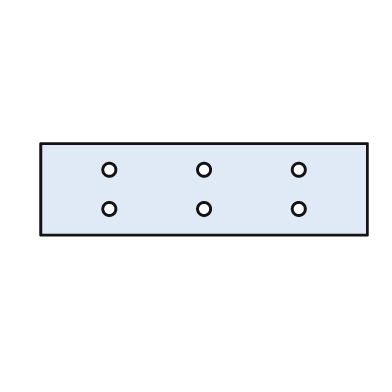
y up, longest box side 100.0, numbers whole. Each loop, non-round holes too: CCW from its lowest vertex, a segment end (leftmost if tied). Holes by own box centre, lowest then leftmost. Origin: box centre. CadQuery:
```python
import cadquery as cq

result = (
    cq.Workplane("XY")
    .moveTo(-50.0, -14.0)
    .lineTo(50.0, -14.0)
    .lineTo(50.0, 14.0)
    .lineTo(-50.0, 14.0)
    .close()
    .moveTo(-29.0, -6.0)
    .circle(2.0)
    .moveTo(0.0, -6.0)
    .circle(2.0)
    .moveTo(29.0, -6.0)
    .circle(2.0)
    .moveTo(-29.0, 6.0)
    .circle(2.0)
    .moveTo(0.0, 6.0)
    .circle(2.0)
    .moveTo(29.0, 6.0)
    .circle(2.0)
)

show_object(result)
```